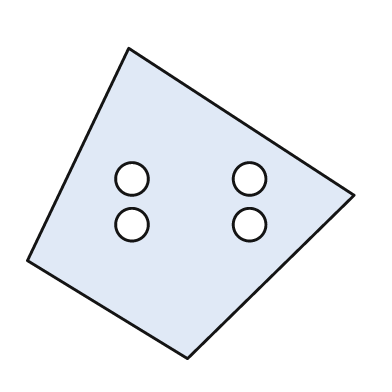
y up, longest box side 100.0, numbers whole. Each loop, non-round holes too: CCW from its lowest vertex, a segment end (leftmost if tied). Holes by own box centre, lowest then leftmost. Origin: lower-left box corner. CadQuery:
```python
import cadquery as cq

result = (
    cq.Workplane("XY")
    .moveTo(49.0, 0.0)
    .lineTo(100.0, 50.0)
    .lineTo(31.0, 95.0)
    .lineTo(0.0, 30.0)
    .close()
    .moveTo(32.0, 41.0)
    .circle(5.0)
    .moveTo(68.0, 41.0)
    .circle(5.0)
    .moveTo(32.0, 55.0)
    .circle(5.0)
    .moveTo(68.0, 55.0)
    .circle(5.0)
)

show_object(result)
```